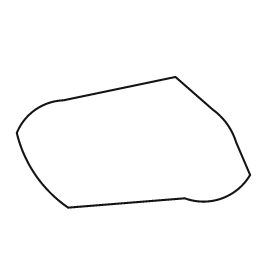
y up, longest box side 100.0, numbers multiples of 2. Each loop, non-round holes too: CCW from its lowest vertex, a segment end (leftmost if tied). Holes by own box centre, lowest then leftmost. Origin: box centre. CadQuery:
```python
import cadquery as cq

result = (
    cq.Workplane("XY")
    .moveTo(-28.0, -28.0)
    .lineTo(22.0, -24.0)
    .threePointArc((38.0, -24.0), (50.0, -14.0))
    .lineTo(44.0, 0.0)
    .threePointArc((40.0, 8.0), (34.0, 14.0))
    .lineTo(18.0, 28.0)
    .lineTo(-30.0, 18.0)
    .threePointArc((-42.0, 14.0), (-50.0, 4.0))
    .threePointArc((-42.0, -14.0), (-28.0, -28.0))
    .close()
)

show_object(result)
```